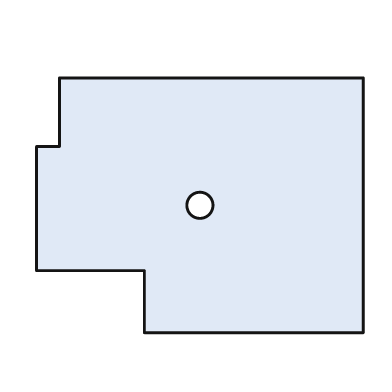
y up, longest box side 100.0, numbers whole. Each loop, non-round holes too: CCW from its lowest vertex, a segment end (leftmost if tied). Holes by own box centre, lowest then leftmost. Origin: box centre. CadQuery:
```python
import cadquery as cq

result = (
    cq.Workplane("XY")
    .moveTo(-17.0, -39.0)
    .lineTo(50.0, -39.0)
    .lineTo(50.0, 39.0)
    .lineTo(-43.0, 39.0)
    .lineTo(-43.0, 18.0)
    .lineTo(-50.0, 18.0)
    .lineTo(-50.0, -20.0)
    .lineTo(-17.0, -20.0)
    .close()
    .moveTo(0.0, 0.0)
    .circle(4.0)
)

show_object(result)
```